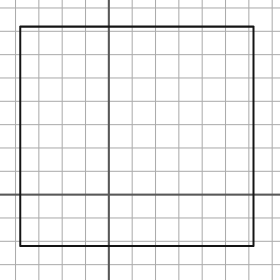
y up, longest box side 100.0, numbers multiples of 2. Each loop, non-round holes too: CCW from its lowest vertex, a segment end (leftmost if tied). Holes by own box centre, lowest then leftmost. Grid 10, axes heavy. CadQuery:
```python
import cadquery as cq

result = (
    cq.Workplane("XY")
    .moveTo(-38.0, -22.0)
    .lineTo(62.0, -22.0)
    .lineTo(62.0, 72.0)
    .lineTo(-38.0, 72.0)
    .close()
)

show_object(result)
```